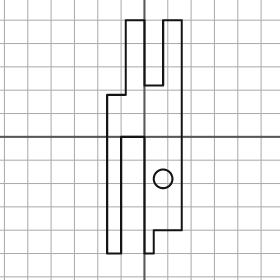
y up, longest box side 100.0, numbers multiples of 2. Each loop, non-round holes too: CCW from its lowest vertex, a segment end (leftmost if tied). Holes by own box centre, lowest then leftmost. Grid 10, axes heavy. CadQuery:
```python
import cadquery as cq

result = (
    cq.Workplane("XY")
    .moveTo(-16.0, -50.0)
    .lineTo(-10.0, -50.0)
    .lineTo(-10.0, 0.0)
    .lineTo(0.0, 0.0)
    .lineTo(0.0, -50.0)
    .lineTo(4.0, -50.0)
    .lineTo(4.0, -40.0)
    .lineTo(16.0, -40.0)
    .lineTo(16.0, 50.0)
    .lineTo(8.0, 50.0)
    .lineTo(8.0, 22.0)
    .lineTo(0.0, 22.0)
    .lineTo(0.0, 50.0)
    .lineTo(-8.0, 50.0)
    .lineTo(-8.0, 18.0)
    .lineTo(-16.0, 18.0)
    .close()
    .moveTo(8.0, -18.0)
    .circle(4.0)
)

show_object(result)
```